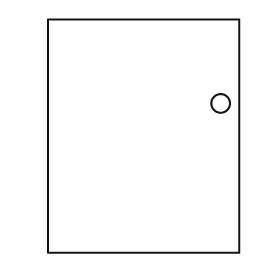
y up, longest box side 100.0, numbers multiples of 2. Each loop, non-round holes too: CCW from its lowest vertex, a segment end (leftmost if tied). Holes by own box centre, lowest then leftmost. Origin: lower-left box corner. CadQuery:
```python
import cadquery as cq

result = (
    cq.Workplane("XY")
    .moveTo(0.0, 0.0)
    .lineTo(82.0, 0.0)
    .lineTo(82.0, 100.0)
    .lineTo(0.0, 100.0)
    .close()
    .moveTo(74.0, 64.0)
    .circle(4.0)
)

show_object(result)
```